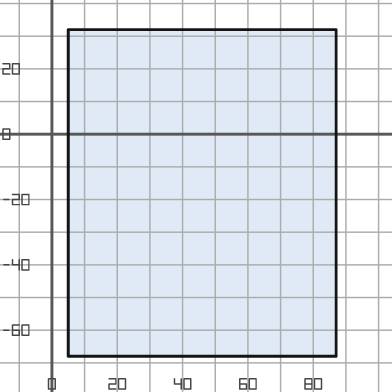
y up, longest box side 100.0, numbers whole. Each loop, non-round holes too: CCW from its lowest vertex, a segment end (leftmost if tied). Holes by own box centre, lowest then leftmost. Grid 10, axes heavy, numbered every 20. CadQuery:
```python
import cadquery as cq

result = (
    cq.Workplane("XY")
    .moveTo(5.0, -68.0)
    .lineTo(87.0, -68.0)
    .lineTo(87.0, 32.0)
    .lineTo(5.0, 32.0)
    .close()
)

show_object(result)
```